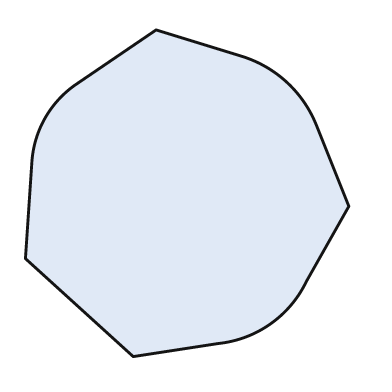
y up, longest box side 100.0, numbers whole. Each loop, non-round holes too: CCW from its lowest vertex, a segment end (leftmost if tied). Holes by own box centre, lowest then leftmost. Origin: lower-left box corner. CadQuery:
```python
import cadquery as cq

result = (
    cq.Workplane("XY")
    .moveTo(33.0, 0.0)
    .lineTo(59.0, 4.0)
    .threePointArc((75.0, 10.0), (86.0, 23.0))
    .lineTo(99.0, 46.0)
    .lineTo(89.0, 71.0)
    .threePointArc((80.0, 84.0), (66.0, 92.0))
    .lineTo(40.0, 100.0)
    .lineTo(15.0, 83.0)
    .threePointArc((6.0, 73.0), (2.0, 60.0))
    .lineTo(0.0, 30.0)
    .close()
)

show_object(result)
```